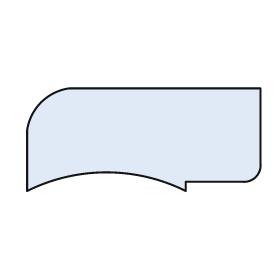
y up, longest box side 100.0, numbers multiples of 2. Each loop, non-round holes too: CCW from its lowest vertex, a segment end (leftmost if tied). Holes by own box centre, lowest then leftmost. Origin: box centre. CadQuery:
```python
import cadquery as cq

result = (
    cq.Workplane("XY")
    .moveTo(-50.0, -22.0)
    .threePointArc((-16.0, -14.0), (18.0, -22.0))
    .lineTo(18.0, -18.0)
    .lineTo(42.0, -18.0)
    .threePointArc((48.0, -16.0), (50.0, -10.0))
    .lineTo(50.0, 22.0)
    .lineTo(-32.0, 22.0)
    .threePointArc((-44.0, 16.0), (-50.0, 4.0))
    .close()
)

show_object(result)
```